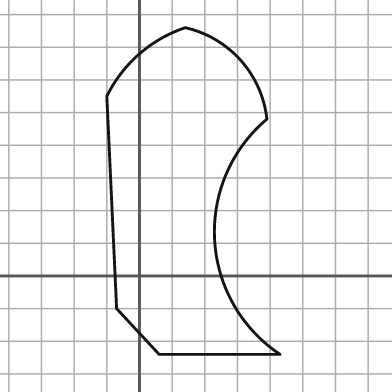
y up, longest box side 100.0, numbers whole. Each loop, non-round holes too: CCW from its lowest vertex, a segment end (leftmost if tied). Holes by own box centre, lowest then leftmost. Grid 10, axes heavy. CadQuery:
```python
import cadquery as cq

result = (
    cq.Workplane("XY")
    .moveTo(6.0, -24.0)
    .lineTo(43.0, -24.0)
    .threePointArc((23.0, 11.0), (39.0, 48.0))
    .threePointArc((31.0, 66.0), (14.0, 76.0))
    .threePointArc((0.0, 68.0), (-10.0, 55.0))
    .lineTo(-7.0, -10.0)
    .close()
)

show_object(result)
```